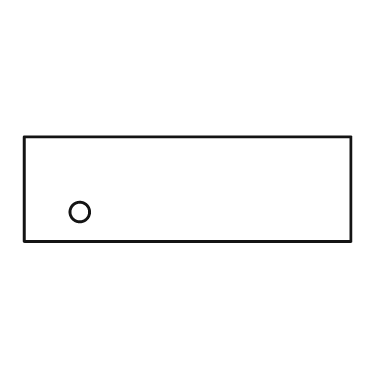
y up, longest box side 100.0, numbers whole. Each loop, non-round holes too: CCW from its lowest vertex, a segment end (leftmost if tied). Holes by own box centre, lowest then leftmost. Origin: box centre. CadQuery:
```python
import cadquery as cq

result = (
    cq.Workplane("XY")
    .moveTo(-50.0, -16.0)
    .lineTo(50.0, -16.0)
    .lineTo(50.0, 16.0)
    .lineTo(-50.0, 16.0)
    .close()
    .moveTo(-33.0, -7.0)
    .circle(3.0)
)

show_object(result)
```